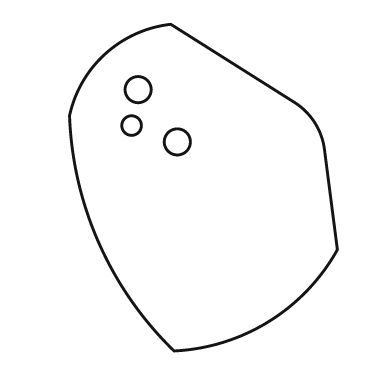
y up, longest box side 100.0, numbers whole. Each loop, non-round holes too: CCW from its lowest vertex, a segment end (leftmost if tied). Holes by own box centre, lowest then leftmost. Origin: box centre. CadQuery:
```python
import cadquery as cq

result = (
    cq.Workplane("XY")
    .moveTo(-9.0, -50.0)
    .threePointArc((20.0, -41.0), (41.0, -19.0))
    .lineTo(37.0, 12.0)
    .threePointArc((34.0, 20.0), (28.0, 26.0))
    .lineTo(-10.0, 50.0)
    .threePointArc((-30.0, 41.0), (-41.0, 22.0))
    .threePointArc((-32.0, -17.0), (-9.0, -50.0))
    .close()
    .moveTo(-8.0, 14.0)
    .circle(4.0)
    .moveTo(-22.0, 19.0)
    .circle(3.0)
    .moveTo(-20.0, 30.0)
    .circle(4.0)
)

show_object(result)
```